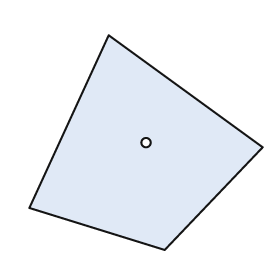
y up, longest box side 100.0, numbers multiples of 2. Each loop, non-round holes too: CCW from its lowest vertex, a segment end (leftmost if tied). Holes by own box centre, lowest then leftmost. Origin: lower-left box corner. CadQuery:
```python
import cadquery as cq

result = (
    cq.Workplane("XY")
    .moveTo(58.0, 0.0)
    .lineTo(100.0, 44.0)
    .lineTo(34.0, 92.0)
    .lineTo(0.0, 18.0)
    .close()
    .moveTo(50.0, 46.0)
    .circle(2.0)
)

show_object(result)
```